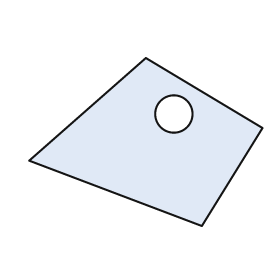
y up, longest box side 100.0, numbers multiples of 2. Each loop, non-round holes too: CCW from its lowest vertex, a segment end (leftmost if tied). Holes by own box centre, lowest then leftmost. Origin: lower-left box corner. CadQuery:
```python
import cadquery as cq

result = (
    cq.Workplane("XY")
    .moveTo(74.0, 0.0)
    .lineTo(100.0, 42.0)
    .lineTo(50.0, 72.0)
    .lineTo(0.0, 28.0)
    .close()
    .moveTo(62.0, 48.0)
    .circle(8.0)
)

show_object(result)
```